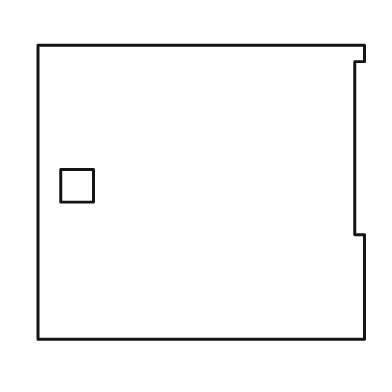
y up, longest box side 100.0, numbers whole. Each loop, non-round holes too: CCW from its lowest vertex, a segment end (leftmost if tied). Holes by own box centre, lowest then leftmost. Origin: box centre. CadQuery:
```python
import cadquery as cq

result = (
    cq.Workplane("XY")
    .moveTo(-50.0, -45.0)
    .lineTo(50.0, -45.0)
    .lineTo(50.0, -13.0)
    .lineTo(47.0, -13.0)
    .lineTo(47.0, 40.0)
    .lineTo(50.0, 40.0)
    .lineTo(50.0, 45.0)
    .lineTo(-50.0, 45.0)
    .close()
    .moveTo(-43.0, -3.0)
    .lineTo(-33.0, -3.0)
    .lineTo(-33.0, 7.0)
    .lineTo(-43.0, 7.0)
    .close()
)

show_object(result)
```